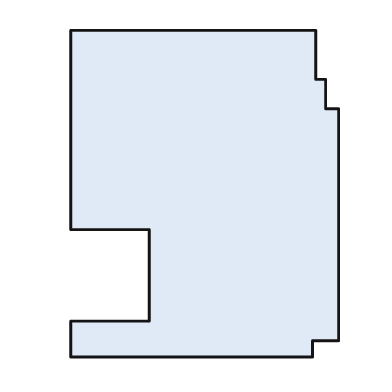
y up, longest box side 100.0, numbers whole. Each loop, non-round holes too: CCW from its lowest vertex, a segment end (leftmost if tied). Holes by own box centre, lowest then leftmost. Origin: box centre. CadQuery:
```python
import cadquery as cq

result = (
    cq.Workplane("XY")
    .moveTo(-41.0, -50.0)
    .lineTo(33.0, -50.0)
    .lineTo(33.0, -45.0)
    .lineTo(41.0, -45.0)
    .lineTo(41.0, 26.0)
    .lineTo(37.0, 26.0)
    .lineTo(37.0, 35.0)
    .lineTo(34.0, 35.0)
    .lineTo(34.0, 50.0)
    .lineTo(-41.0, 50.0)
    .lineTo(-41.0, -11.0)
    .lineTo(-17.0, -11.0)
    .lineTo(-17.0, -39.0)
    .lineTo(-41.0, -39.0)
    .close()
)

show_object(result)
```